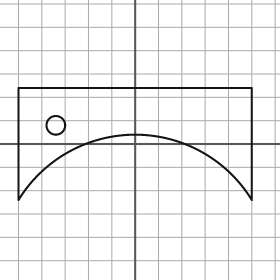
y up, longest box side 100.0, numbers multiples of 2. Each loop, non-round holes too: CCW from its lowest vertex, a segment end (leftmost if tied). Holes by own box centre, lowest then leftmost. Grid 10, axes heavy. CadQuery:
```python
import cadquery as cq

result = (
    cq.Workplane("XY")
    .moveTo(-50.0, -24.0)
    .threePointArc((0.0, 4.0), (50.0, -24.0))
    .lineTo(50.0, 24.0)
    .lineTo(-50.0, 24.0)
    .close()
    .moveTo(-34.0, 8.0)
    .circle(4.0)
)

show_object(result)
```